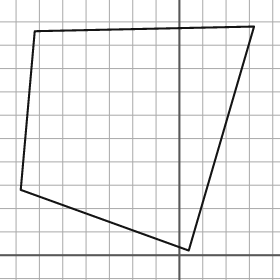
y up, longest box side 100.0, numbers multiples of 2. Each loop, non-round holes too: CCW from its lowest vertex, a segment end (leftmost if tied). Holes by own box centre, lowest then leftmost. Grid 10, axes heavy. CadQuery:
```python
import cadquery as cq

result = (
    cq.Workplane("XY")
    .moveTo(4.0, 2.0)
    .lineTo(32.0, 98.0)
    .lineTo(-62.0, 96.0)
    .lineTo(-68.0, 28.0)
    .close()
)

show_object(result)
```